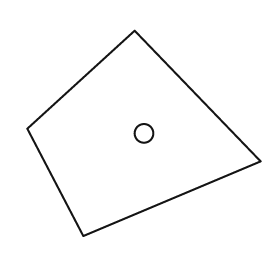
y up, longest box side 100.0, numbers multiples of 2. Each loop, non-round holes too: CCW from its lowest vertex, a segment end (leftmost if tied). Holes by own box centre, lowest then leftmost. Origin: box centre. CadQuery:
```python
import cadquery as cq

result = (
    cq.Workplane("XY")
    .moveTo(-26.0, -44.0)
    .lineTo(50.0, -12.0)
    .lineTo(-4.0, 44.0)
    .lineTo(-50.0, 2.0)
    .close()
    .moveTo(0.0, 0.0)
    .circle(4.0)
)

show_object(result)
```